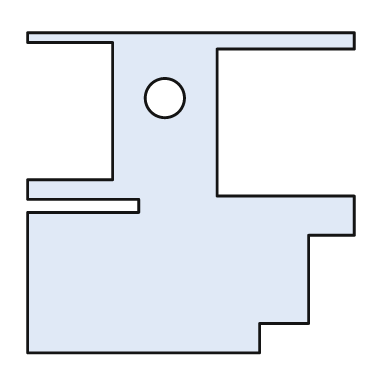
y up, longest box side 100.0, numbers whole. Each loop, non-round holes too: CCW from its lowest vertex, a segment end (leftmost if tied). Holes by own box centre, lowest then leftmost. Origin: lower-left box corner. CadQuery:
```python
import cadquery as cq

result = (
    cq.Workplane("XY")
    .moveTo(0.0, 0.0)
    .lineTo(71.0, 0.0)
    .lineTo(71.0, 9.0)
    .lineTo(86.0, 9.0)
    .lineTo(86.0, 36.0)
    .lineTo(100.0, 36.0)
    .lineTo(100.0, 48.0)
    .lineTo(58.0, 48.0)
    .lineTo(58.0, 93.0)
    .lineTo(100.0, 93.0)
    .lineTo(100.0, 98.0)
    .lineTo(0.0, 98.0)
    .lineTo(0.0, 95.0)
    .lineTo(26.0, 95.0)
    .lineTo(26.0, 53.0)
    .lineTo(0.0, 53.0)
    .lineTo(0.0, 47.0)
    .lineTo(34.0, 47.0)
    .lineTo(34.0, 43.0)
    .lineTo(0.0, 43.0)
    .close()
    .moveTo(42.0, 78.0)
    .circle(6.0)
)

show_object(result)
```